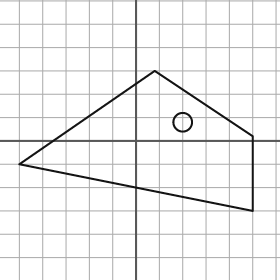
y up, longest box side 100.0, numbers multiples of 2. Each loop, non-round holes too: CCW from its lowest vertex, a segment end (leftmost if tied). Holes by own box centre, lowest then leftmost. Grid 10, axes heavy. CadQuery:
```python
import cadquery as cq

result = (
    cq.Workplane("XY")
    .moveTo(50.0, -30.0)
    .lineTo(50.0, 2.0)
    .lineTo(8.0, 30.0)
    .lineTo(-50.0, -10.0)
    .close()
    .moveTo(20.0, 8.0)
    .circle(4.0)
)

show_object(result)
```